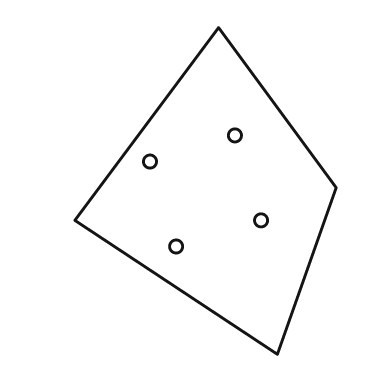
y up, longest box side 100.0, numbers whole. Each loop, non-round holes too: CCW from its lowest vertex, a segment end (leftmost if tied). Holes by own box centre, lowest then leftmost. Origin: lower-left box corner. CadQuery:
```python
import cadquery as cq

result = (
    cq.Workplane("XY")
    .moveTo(62.0, 0.0)
    .lineTo(80.0, 51.0)
    .lineTo(44.0, 100.0)
    .lineTo(0.0, 41.0)
    .close()
    .moveTo(31.0, 33.0)
    .circle(2.0)
    .moveTo(57.0, 41.0)
    .circle(2.0)
    .moveTo(23.0, 59.0)
    .circle(2.0)
    .moveTo(49.0, 67.0)
    .circle(2.0)
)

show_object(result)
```